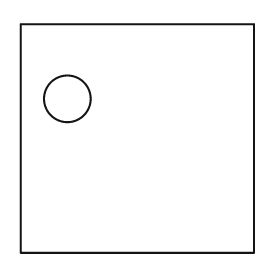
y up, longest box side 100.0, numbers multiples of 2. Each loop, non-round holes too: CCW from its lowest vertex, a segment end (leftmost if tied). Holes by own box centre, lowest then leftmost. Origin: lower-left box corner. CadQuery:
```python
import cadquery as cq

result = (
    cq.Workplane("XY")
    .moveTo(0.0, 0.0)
    .lineTo(100.0, 0.0)
    .lineTo(100.0, 98.0)
    .lineTo(0.0, 98.0)
    .close()
    .moveTo(20.0, 66.0)
    .circle(10.0)
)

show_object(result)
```